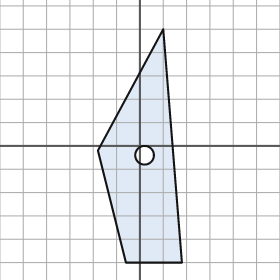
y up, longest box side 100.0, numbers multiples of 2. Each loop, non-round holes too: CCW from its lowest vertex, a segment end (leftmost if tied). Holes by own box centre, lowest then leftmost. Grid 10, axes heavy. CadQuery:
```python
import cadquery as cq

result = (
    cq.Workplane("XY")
    .moveTo(-6.0, -50.0)
    .lineTo(18.0, -50.0)
    .lineTo(10.0, 50.0)
    .lineTo(-18.0, -2.0)
    .close()
    .moveTo(2.0, -4.0)
    .circle(4.0)
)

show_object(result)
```